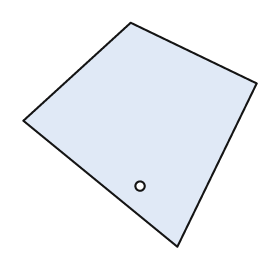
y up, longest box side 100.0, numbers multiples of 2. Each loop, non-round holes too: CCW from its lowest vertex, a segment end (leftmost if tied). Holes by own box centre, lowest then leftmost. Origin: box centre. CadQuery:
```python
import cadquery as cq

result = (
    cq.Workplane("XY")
    .moveTo(16.0, -48.0)
    .lineTo(50.0, 22.0)
    .lineTo(-4.0, 48.0)
    .lineTo(-50.0, 6.0)
    .close()
    .moveTo(0.0, -22.0)
    .circle(2.0)
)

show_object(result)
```